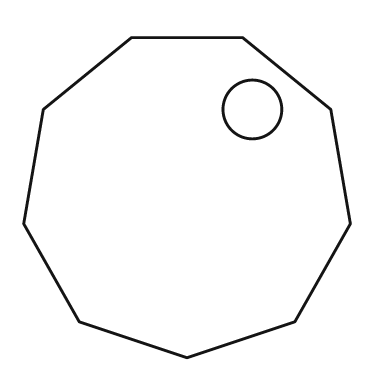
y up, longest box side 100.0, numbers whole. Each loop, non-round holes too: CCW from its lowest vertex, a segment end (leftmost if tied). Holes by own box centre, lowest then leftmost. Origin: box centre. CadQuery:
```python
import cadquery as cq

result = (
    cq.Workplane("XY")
    .moveTo(0.0, -49.0)
    .lineTo(33.0, -38.0)
    .lineTo(50.0, -8.0)
    .lineTo(44.0, 27.0)
    .lineTo(17.0, 49.0)
    .lineTo(-17.0, 49.0)
    .lineTo(-44.0, 27.0)
    .lineTo(-50.0, -8.0)
    .lineTo(-33.0, -38.0)
    .close()
    .moveTo(20.0, 27.0)
    .circle(9.0)
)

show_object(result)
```